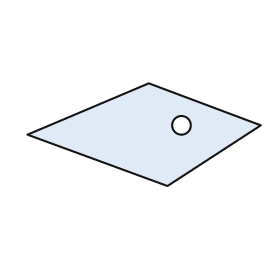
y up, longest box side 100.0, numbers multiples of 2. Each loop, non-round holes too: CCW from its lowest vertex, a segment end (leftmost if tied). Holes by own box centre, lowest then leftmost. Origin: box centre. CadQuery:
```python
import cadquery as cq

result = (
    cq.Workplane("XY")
    .moveTo(10.0, -22.0)
    .lineTo(50.0, 4.0)
    .lineTo(2.0, 22.0)
    .lineTo(-50.0, 0.0)
    .close()
    .moveTo(16.0, 4.0)
    .circle(4.0)
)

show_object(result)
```